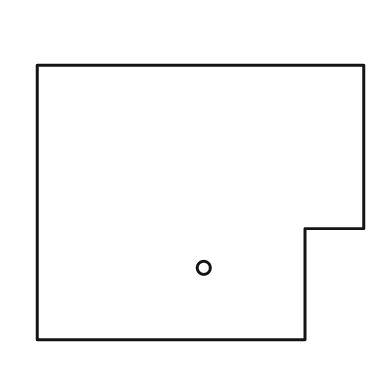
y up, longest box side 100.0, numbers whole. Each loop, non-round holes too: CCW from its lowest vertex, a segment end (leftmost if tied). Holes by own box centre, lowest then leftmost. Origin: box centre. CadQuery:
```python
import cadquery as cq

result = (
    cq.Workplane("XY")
    .moveTo(-50.0, -42.0)
    .lineTo(32.0, -42.0)
    .lineTo(32.0, -8.0)
    .lineTo(50.0, -8.0)
    .lineTo(50.0, 42.0)
    .lineTo(-50.0, 42.0)
    .close()
    .moveTo(1.0, -20.0)
    .circle(2.0)
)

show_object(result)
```